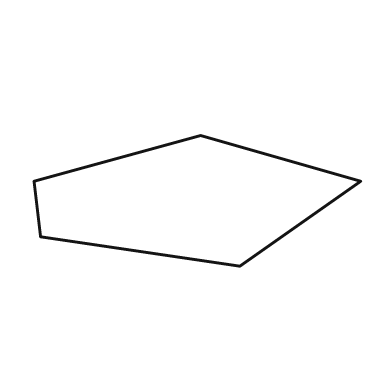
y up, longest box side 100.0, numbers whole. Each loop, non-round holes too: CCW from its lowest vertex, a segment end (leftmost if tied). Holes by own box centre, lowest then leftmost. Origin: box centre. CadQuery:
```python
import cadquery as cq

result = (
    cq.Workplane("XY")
    .moveTo(13.0, -20.0)
    .lineTo(50.0, 6.0)
    .lineTo(1.0, 20.0)
    .lineTo(-50.0, 6.0)
    .lineTo(-48.0, -11.0)
    .close()
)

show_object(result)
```